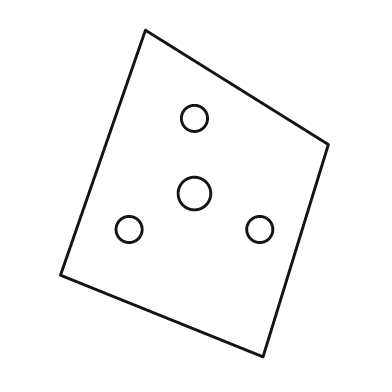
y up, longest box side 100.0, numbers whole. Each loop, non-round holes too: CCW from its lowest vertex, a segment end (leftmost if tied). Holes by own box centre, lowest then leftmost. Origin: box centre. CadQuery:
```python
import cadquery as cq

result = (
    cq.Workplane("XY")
    .moveTo(21.0, -50.0)
    .lineTo(41.0, 15.0)
    .lineTo(-15.0, 50.0)
    .lineTo(-41.0, -25.0)
    .close()
    .moveTo(-20.0, -11.0)
    .circle(4.0)
    .moveTo(20.0, -11.0)
    .circle(4.0)
    .moveTo(0.0, 0.0)
    .circle(5.0)
    .moveTo(0.0, 23.0)
    .circle(4.0)
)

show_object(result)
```